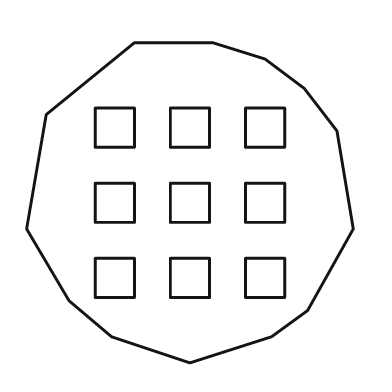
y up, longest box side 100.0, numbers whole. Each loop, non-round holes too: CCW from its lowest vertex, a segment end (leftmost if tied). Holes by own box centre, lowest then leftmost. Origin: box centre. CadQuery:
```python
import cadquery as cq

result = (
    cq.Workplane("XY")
    .moveTo(0.0, -49.0)
    .lineTo(25.0, -41.0)
    .lineTo(36.0, -33.0)
    .lineTo(50.0, -8.0)
    .lineTo(45.0, 22.0)
    .lineTo(35.0, 35.0)
    .lineTo(23.0, 44.0)
    .lineTo(7.0, 49.0)
    .lineTo(-17.0, 49.0)
    .lineTo(-44.0, 27.0)
    .lineTo(-50.0, -8.0)
    .lineTo(-37.0, -30.0)
    .lineTo(-24.0, -41.0)
    .close()
    .moveTo(-29.0, -29.0)
    .lineTo(-17.0, -29.0)
    .lineTo(-17.0, -17.0)
    .lineTo(-29.0, -17.0)
    .close()
    .moveTo(-6.0, -29.0)
    .lineTo(6.0, -29.0)
    .lineTo(6.0, -17.0)
    .lineTo(-6.0, -17.0)
    .close()
    .moveTo(17.0, -29.0)
    .lineTo(29.0, -29.0)
    .lineTo(29.0, -17.0)
    .lineTo(17.0, -17.0)
    .close()
    .moveTo(-29.0, -6.0)
    .lineTo(-17.0, -6.0)
    .lineTo(-17.0, 6.0)
    .lineTo(-29.0, 6.0)
    .close()
    .moveTo(-6.0, -6.0)
    .lineTo(6.0, -6.0)
    .lineTo(6.0, 6.0)
    .lineTo(-6.0, 6.0)
    .close()
    .moveTo(17.0, -6.0)
    .lineTo(29.0, -6.0)
    .lineTo(29.0, 6.0)
    .lineTo(17.0, 6.0)
    .close()
    .moveTo(-29.0, 17.0)
    .lineTo(-17.0, 17.0)
    .lineTo(-17.0, 29.0)
    .lineTo(-29.0, 29.0)
    .close()
    .moveTo(-6.0, 17.0)
    .lineTo(6.0, 17.0)
    .lineTo(6.0, 29.0)
    .lineTo(-6.0, 29.0)
    .close()
    .moveTo(17.0, 17.0)
    .lineTo(29.0, 17.0)
    .lineTo(29.0, 29.0)
    .lineTo(17.0, 29.0)
    .close()
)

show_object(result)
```